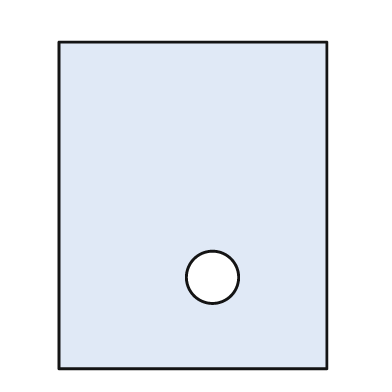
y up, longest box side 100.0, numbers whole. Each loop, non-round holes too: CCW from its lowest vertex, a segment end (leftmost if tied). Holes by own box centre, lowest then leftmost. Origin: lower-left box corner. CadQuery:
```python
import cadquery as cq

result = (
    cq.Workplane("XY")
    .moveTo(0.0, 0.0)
    .lineTo(82.0, 0.0)
    .lineTo(82.0, 100.0)
    .lineTo(0.0, 100.0)
    .close()
    .moveTo(47.0, 28.0)
    .circle(8.0)
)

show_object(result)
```